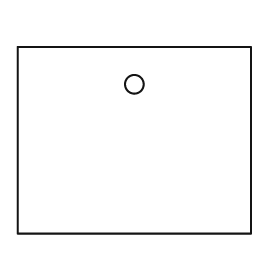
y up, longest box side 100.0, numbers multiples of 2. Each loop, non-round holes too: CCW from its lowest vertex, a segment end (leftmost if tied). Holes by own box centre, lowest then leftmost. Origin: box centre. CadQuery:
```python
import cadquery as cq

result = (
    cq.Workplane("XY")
    .moveTo(-50.0, -40.0)
    .lineTo(50.0, -40.0)
    .lineTo(50.0, 40.0)
    .lineTo(-50.0, 40.0)
    .close()
    .moveTo(0.0, 24.0)
    .circle(4.0)
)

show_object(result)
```